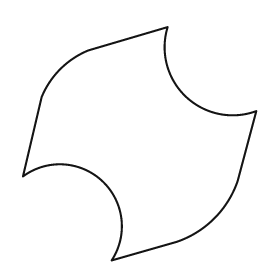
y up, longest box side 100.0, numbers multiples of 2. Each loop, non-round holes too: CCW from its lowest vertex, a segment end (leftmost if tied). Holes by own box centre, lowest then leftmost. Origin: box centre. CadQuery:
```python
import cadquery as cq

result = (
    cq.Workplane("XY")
    .moveTo(-12.0, -50.0)
    .lineTo(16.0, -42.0)
    .threePointArc((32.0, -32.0), (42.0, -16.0))
    .lineTo(50.0, 14.0)
    .threePointArc((20.0, 20.0), (12.0, 50.0))
    .lineTo(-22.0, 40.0)
    .threePointArc((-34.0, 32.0), (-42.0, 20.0))
    .lineTo(-50.0, -14.0)
    .threePointArc((-16.0, -16.0), (-12.0, -50.0))
    .close()
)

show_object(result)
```